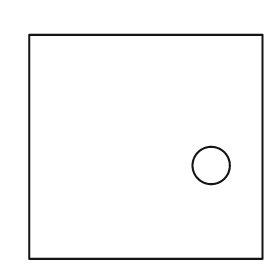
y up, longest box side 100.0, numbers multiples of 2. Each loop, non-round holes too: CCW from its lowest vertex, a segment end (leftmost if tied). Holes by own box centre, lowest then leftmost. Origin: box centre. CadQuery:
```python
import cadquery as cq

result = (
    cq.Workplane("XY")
    .moveTo(-50.0, -48.0)
    .lineTo(50.0, -48.0)
    .lineTo(50.0, 48.0)
    .lineTo(-50.0, 48.0)
    .close()
    .moveTo(28.0, -8.0)
    .circle(8.0)
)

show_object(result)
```